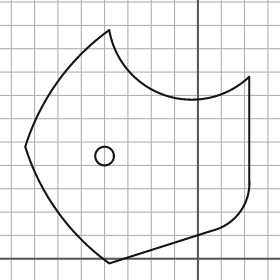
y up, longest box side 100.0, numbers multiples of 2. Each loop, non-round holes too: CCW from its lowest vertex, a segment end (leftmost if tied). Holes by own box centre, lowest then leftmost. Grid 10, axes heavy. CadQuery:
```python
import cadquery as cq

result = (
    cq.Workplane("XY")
    .moveTo(-38.0, -2.0)
    .lineTo(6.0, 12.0)
    .threePointArc((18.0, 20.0), (22.0, 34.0))
    .lineTo(22.0, 78.0)
    .threePointArc((-14.0, 70.0), (-38.0, 98.0))
    .threePointArc((-60.0, 76.0), (-74.0, 48.0))
    .threePointArc((-60.0, 20.0), (-38.0, -2.0))
    .close()
    .moveTo(-40.0, 44.0)
    .circle(4.0)
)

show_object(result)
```